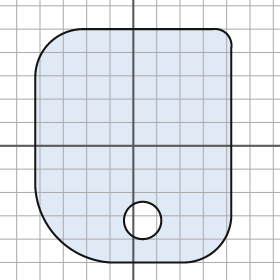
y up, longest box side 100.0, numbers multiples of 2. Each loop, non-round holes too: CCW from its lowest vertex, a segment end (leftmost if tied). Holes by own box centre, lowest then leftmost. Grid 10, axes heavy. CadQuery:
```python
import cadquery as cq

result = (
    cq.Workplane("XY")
    .moveTo(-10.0, -50.0)
    .lineTo(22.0, -50.0)
    .threePointArc((36.0, -44.0), (42.0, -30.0))
    .lineTo(42.0, 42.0)
    .threePointArc((40.0, 48.0), (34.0, 50.0))
    .lineTo(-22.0, 50.0)
    .threePointArc((-36.0, 44.0), (-42.0, 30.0))
    .lineTo(-42.0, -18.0)
    .threePointArc((-32.0, -40.0), (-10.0, -50.0))
    .close()
    .moveTo(4.0, -32.0)
    .circle(8.0)
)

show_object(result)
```